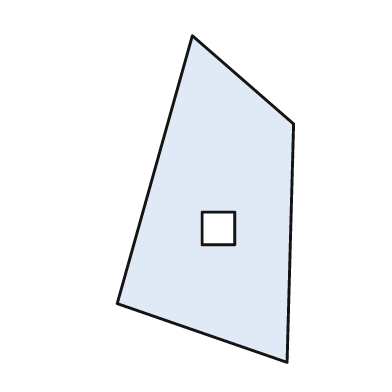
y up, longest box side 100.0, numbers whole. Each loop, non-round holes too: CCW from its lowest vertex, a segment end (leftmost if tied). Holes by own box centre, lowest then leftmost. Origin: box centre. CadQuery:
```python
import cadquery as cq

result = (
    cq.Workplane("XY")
    .moveTo(25.0, -50.0)
    .lineTo(27.0, 23.0)
    .lineTo(-4.0, 50.0)
    .lineTo(-27.0, -32.0)
    .close()
    .moveTo(-1.0, -14.0)
    .lineTo(9.0, -14.0)
    .lineTo(9.0, -4.0)
    .lineTo(-1.0, -4.0)
    .close()
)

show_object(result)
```